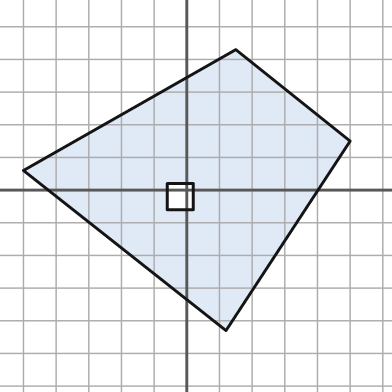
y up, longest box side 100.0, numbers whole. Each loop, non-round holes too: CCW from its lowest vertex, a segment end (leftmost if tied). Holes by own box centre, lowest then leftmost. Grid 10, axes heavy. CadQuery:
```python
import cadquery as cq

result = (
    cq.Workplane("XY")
    .moveTo(12.0, -43.0)
    .lineTo(50.0, 15.0)
    .lineTo(15.0, 43.0)
    .lineTo(-50.0, 6.0)
    .close()
    .moveTo(-6.0, -6.0)
    .lineTo(2.0, -6.0)
    .lineTo(2.0, 2.0)
    .lineTo(-6.0, 2.0)
    .close()
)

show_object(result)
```